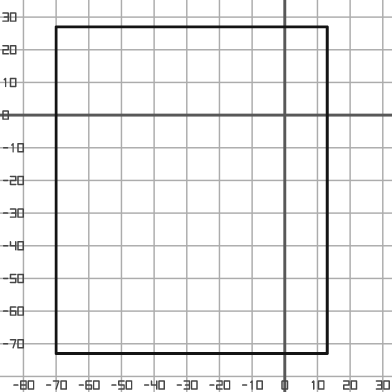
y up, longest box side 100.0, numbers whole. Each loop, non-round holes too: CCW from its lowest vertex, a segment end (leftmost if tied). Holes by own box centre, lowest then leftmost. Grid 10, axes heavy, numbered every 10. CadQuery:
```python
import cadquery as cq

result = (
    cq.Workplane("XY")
    .moveTo(-70.0, -73.0)
    .lineTo(13.0, -73.0)
    .lineTo(13.0, 27.0)
    .lineTo(-70.0, 27.0)
    .close()
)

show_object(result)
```